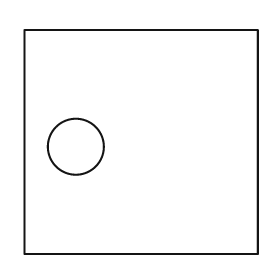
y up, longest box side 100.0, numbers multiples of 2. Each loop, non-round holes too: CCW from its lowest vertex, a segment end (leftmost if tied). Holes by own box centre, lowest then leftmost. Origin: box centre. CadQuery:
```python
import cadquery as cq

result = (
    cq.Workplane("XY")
    .moveTo(-50.0, -48.0)
    .lineTo(50.0, -48.0)
    .lineTo(50.0, 48.0)
    .lineTo(-50.0, 48.0)
    .close()
    .moveTo(-28.0, -2.0)
    .circle(12.0)
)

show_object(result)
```